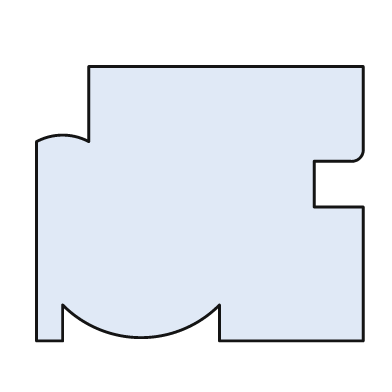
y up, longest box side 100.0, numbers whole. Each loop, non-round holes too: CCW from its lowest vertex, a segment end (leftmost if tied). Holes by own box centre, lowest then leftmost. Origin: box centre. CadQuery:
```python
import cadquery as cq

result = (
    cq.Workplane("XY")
    .moveTo(-50.0, -42.0)
    .lineTo(-42.0, -42.0)
    .lineTo(-42.0, -31.0)
    .threePointArc((-18.0, -41.0), (6.0, -31.0))
    .lineTo(6.0, -42.0)
    .lineTo(50.0, -42.0)
    .lineTo(50.0, -1.0)
    .lineTo(35.0, -1.0)
    .lineTo(35.0, 13.0)
    .lineTo(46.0, 13.0)
    .threePointArc((49.0, 14.0), (50.0, 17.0))
    .lineTo(50.0, 42.0)
    .lineTo(-34.0, 42.0)
    .lineTo(-34.0, 19.0)
    .threePointArc((-42.0, 21.0), (-50.0, 19.0))
    .close()
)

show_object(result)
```